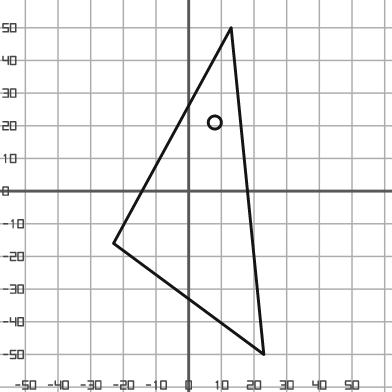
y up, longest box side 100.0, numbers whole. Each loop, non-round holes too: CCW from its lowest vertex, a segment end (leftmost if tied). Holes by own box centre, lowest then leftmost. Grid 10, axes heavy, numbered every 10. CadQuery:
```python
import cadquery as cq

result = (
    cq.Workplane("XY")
    .moveTo(23.0, -50.0)
    .lineTo(13.0, 50.0)
    .lineTo(-23.0, -16.0)
    .close()
    .moveTo(8.0, 21.0)
    .circle(2.0)
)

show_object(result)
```